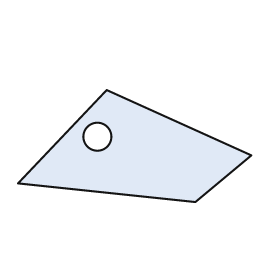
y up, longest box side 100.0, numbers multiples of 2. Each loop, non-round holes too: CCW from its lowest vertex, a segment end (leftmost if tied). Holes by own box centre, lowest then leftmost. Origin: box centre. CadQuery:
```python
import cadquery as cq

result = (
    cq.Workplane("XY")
    .moveTo(26.0, -24.0)
    .lineTo(50.0, -4.0)
    .lineTo(-12.0, 24.0)
    .lineTo(-50.0, -16.0)
    .close()
    .moveTo(-16.0, 4.0)
    .circle(6.0)
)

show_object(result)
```